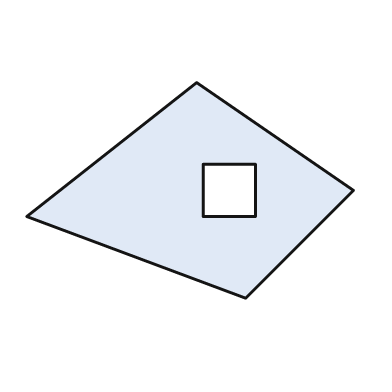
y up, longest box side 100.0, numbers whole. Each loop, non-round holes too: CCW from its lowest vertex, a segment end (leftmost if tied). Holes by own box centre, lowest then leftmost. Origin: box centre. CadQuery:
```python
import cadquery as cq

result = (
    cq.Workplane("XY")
    .moveTo(17.0, -33.0)
    .lineTo(50.0, 0.0)
    .lineTo(2.0, 33.0)
    .lineTo(-50.0, -8.0)
    .close()
    .moveTo(4.0, -8.0)
    .lineTo(20.0, -8.0)
    .lineTo(20.0, 8.0)
    .lineTo(4.0, 8.0)
    .close()
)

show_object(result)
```